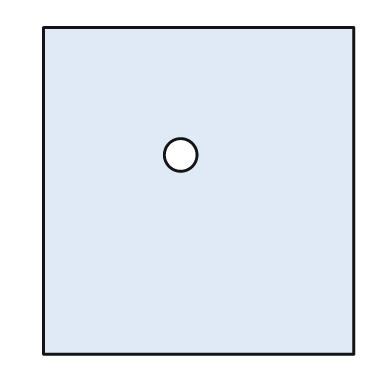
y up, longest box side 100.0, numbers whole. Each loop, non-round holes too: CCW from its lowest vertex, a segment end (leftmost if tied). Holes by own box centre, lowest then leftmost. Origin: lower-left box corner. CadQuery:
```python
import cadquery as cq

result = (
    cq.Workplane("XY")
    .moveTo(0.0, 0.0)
    .lineTo(95.0, 0.0)
    .lineTo(95.0, 100.0)
    .lineTo(0.0, 100.0)
    .close()
    .moveTo(42.0, 61.0)
    .circle(5.0)
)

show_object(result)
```